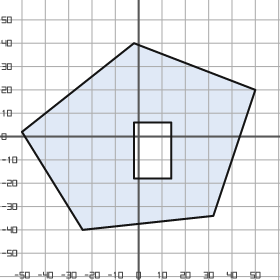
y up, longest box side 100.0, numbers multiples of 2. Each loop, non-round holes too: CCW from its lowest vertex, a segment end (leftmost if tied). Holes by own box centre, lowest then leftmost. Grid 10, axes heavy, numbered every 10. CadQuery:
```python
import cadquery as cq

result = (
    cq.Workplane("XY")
    .moveTo(-24.0, -40.0)
    .lineTo(32.0, -34.0)
    .lineTo(50.0, 20.0)
    .lineTo(-2.0, 40.0)
    .lineTo(-50.0, 2.0)
    .close()
    .moveTo(-2.0, -18.0)
    .lineTo(14.0, -18.0)
    .lineTo(14.0, 6.0)
    .lineTo(-2.0, 6.0)
    .close()
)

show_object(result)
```